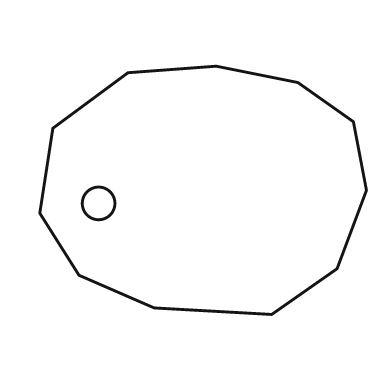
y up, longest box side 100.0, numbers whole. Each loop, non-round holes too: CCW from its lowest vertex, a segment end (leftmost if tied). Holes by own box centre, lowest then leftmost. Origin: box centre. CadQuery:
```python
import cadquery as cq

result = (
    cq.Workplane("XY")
    .moveTo(21.0, -38.0)
    .lineTo(41.0, -24.0)
    .lineTo(50.0, 0.0)
    .lineTo(46.0, 21.0)
    .lineTo(29.0, 33.0)
    .lineTo(4.0, 38.0)
    .lineTo(-23.0, 36.0)
    .lineTo(-46.0, 19.0)
    .lineTo(-50.0, -7.0)
    .lineTo(-38.0, -26.0)
    .lineTo(-15.0, -36.0)
    .close()
    .moveTo(-32.0, -4.0)
    .circle(5.0)
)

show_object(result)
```